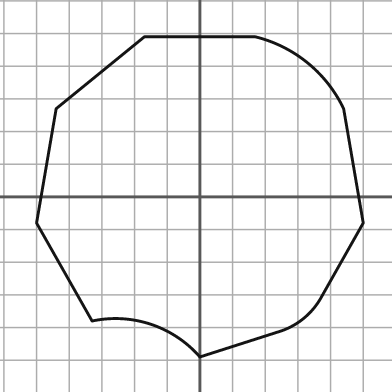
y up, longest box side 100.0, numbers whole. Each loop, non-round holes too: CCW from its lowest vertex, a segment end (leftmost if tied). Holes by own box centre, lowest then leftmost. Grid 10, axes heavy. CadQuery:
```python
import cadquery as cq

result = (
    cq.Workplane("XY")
    .moveTo(0.0, -49.0)
    .lineTo(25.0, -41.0)
    .threePointArc((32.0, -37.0), (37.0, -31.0))
    .lineTo(50.0, -8.0)
    .lineTo(44.0, 27.0)
    .threePointArc((33.0, 41.0), (17.0, 49.0))
    .lineTo(-17.0, 49.0)
    .lineTo(-44.0, 27.0)
    .lineTo(-50.0, -8.0)
    .lineTo(-33.0, -38.0)
    .threePointArc((-15.0, -39.0), (0.0, -49.0))
    .close()
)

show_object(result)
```